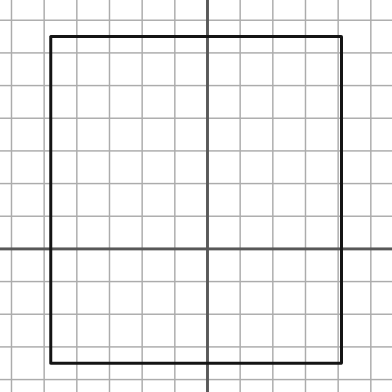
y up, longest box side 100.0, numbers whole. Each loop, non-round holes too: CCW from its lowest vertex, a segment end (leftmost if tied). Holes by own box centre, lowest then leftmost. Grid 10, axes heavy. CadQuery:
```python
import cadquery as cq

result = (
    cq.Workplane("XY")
    .moveTo(-48.0, -35.0)
    .lineTo(41.0, -35.0)
    .lineTo(41.0, 65.0)
    .lineTo(-48.0, 65.0)
    .close()
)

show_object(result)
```